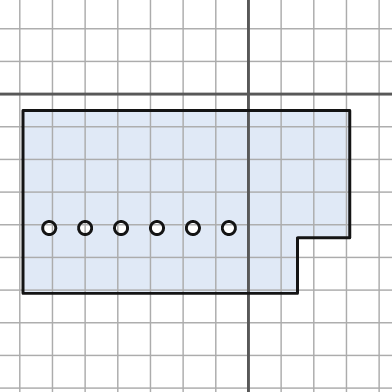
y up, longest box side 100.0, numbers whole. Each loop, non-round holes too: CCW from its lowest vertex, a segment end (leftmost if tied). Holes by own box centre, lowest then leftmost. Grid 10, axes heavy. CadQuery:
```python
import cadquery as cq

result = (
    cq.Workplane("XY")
    .moveTo(-69.0, -61.0)
    .lineTo(15.0, -61.0)
    .lineTo(15.0, -44.0)
    .lineTo(31.0, -44.0)
    .lineTo(31.0, -5.0)
    .lineTo(-69.0, -5.0)
    .close()
    .moveTo(-61.0, -41.0)
    .circle(2.0)
    .moveTo(-50.0, -41.0)
    .circle(2.0)
    .moveTo(-39.0, -41.0)
    .circle(2.0)
    .moveTo(-28.0, -41.0)
    .circle(2.0)
    .moveTo(-17.0, -41.0)
    .circle(2.0)
    .moveTo(-6.0, -41.0)
    .circle(2.0)
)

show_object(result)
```